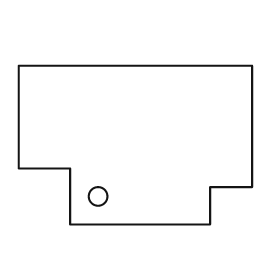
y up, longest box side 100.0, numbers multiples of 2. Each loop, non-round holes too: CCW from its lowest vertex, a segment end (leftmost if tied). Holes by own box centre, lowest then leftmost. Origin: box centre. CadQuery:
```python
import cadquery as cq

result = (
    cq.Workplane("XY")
    .moveTo(-28.0, -34.0)
    .lineTo(32.0, -34.0)
    .lineTo(32.0, -18.0)
    .lineTo(50.0, -18.0)
    .lineTo(50.0, 34.0)
    .lineTo(-50.0, 34.0)
    .lineTo(-50.0, -10.0)
    .lineTo(-28.0, -10.0)
    .close()
    .moveTo(-16.0, -22.0)
    .circle(4.0)
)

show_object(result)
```